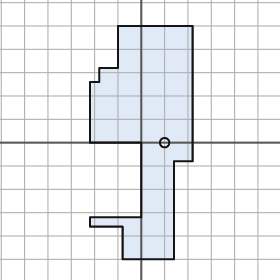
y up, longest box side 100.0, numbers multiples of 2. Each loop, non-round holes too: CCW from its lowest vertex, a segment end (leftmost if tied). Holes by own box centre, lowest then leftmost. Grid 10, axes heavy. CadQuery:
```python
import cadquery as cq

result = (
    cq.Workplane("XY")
    .moveTo(-8.0, -50.0)
    .lineTo(14.0, -50.0)
    .lineTo(14.0, -8.0)
    .lineTo(22.0, -8.0)
    .lineTo(22.0, 50.0)
    .lineTo(-10.0, 50.0)
    .lineTo(-10.0, 32.0)
    .lineTo(-18.0, 32.0)
    .lineTo(-18.0, 26.0)
    .lineTo(-22.0, 26.0)
    .lineTo(-22.0, 0.0)
    .lineTo(0.0, 0.0)
    .lineTo(0.0, -32.0)
    .lineTo(-22.0, -32.0)
    .lineTo(-22.0, -36.0)
    .lineTo(-8.0, -36.0)
    .close()
    .moveTo(10.0, 0.0)
    .circle(2.0)
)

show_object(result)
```